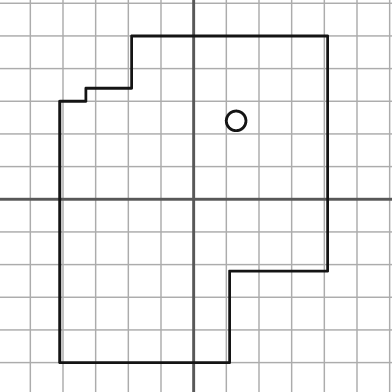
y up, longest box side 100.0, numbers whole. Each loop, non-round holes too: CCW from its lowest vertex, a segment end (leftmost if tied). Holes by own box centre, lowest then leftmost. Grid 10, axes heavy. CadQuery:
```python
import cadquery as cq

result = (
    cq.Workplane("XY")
    .moveTo(-41.0, -50.0)
    .lineTo(11.0, -50.0)
    .lineTo(11.0, -22.0)
    .lineTo(41.0, -22.0)
    .lineTo(41.0, 50.0)
    .lineTo(-19.0, 50.0)
    .lineTo(-19.0, 34.0)
    .lineTo(-33.0, 34.0)
    .lineTo(-33.0, 30.0)
    .lineTo(-41.0, 30.0)
    .close()
    .moveTo(13.0, 24.0)
    .circle(3.0)
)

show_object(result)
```